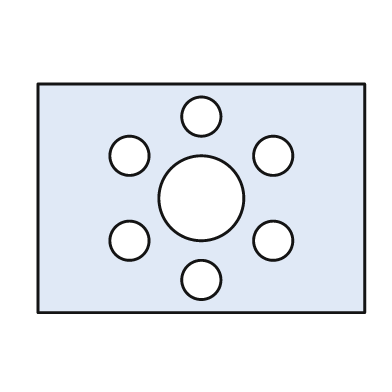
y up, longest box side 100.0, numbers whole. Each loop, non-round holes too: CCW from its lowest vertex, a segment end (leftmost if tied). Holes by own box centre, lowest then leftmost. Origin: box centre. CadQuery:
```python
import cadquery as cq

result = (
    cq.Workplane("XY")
    .moveTo(-50.0, -35.0)
    .lineTo(50.0, -35.0)
    .lineTo(50.0, 35.0)
    .lineTo(-50.0, 35.0)
    .close()
    .moveTo(0.0, -25.0)
    .circle(6.0)
    .moveTo(-22.0, -13.0)
    .circle(6.0)
    .moveTo(22.0, -13.0)
    .circle(6.0)
    .moveTo(0.0, 0.0)
    .circle(13.0)
    .moveTo(-22.0, 13.0)
    .circle(6.0)
    .moveTo(22.0, 13.0)
    .circle(6.0)
    .moveTo(0.0, 25.0)
    .circle(6.0)
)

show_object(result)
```